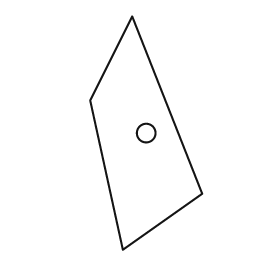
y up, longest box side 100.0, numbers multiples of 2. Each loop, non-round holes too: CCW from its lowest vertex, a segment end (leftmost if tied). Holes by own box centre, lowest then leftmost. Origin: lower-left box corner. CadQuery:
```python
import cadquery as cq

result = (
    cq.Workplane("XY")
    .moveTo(14.0, 0.0)
    .lineTo(48.0, 24.0)
    .lineTo(18.0, 100.0)
    .lineTo(0.0, 64.0)
    .close()
    .moveTo(24.0, 50.0)
    .circle(4.0)
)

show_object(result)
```